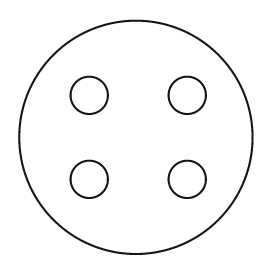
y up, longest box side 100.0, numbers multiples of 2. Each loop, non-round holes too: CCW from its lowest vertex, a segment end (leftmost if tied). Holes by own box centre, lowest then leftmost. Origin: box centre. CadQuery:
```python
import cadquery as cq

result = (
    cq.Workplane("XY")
    .moveTo(0.0, 0.0)
    .circle(50.0)
    .moveTo(-20.0, -18.0)
    .circle(8.0)
    .moveTo(22.0, -18.0)
    .circle(8.0)
    .moveTo(-20.0, 18.0)
    .circle(8.0)
    .moveTo(22.0, 18.0)
    .circle(8.0)
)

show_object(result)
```